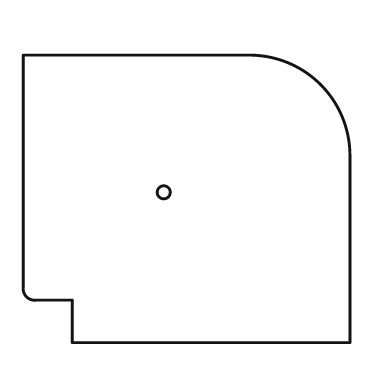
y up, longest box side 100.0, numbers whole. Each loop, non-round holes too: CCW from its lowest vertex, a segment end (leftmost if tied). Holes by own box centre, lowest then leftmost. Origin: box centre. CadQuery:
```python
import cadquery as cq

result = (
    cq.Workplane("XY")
    .moveTo(-35.0, -44.0)
    .lineTo(50.0, -44.0)
    .lineTo(50.0, 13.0)
    .threePointArc((41.0, 35.0), (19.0, 44.0))
    .lineTo(-50.0, 44.0)
    .lineTo(-50.0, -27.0)
    .threePointArc((-49.0, -30.0), (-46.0, -31.0))
    .lineTo(-35.0, -31.0)
    .close()
    .moveTo(-7.0, 2.0)
    .circle(2.0)
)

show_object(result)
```